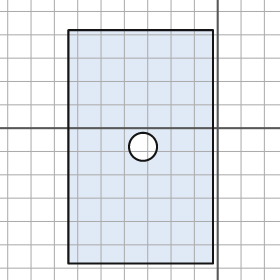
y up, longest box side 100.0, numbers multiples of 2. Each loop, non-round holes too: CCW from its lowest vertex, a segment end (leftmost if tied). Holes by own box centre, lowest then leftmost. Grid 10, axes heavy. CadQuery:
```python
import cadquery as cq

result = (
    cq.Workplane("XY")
    .moveTo(-64.0, -58.0)
    .lineTo(-2.0, -58.0)
    .lineTo(-2.0, 42.0)
    .lineTo(-64.0, 42.0)
    .close()
    .moveTo(-32.0, -8.0)
    .circle(6.0)
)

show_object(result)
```